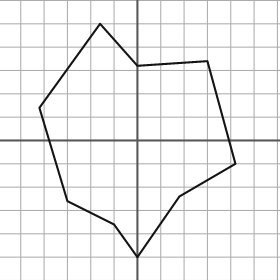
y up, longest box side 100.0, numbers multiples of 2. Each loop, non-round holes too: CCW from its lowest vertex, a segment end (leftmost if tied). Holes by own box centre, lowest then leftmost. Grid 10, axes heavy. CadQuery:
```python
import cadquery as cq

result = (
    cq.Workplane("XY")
    .moveTo(0.0, -50.0)
    .lineTo(18.0, -24.0)
    .lineTo(42.0, -10.0)
    .lineTo(30.0, 34.0)
    .lineTo(0.0, 32.0)
    .lineTo(-16.0, 50.0)
    .lineTo(-42.0, 14.0)
    .lineTo(-30.0, -26.0)
    .lineTo(-10.0, -36.0)
    .close()
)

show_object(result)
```